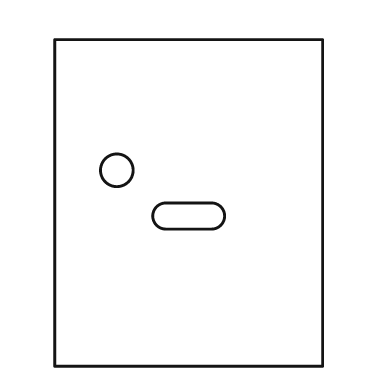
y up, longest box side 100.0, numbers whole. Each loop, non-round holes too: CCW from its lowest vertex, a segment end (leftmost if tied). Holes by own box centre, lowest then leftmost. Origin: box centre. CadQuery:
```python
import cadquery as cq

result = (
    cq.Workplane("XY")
    .moveTo(-41.0, -50.0)
    .lineTo(41.0, -50.0)
    .lineTo(41.0, 50.0)
    .lineTo(-41.0, 50.0)
    .close()
    .moveTo(-7.0, -8.0)
    .lineTo(7.0, -8.0)
    .threePointArc((11.0, -4.0), (7.0, 0.0))
    .lineTo(-7.0, 0.0)
    .threePointArc((-11.0, -4.0), (-7.0, -8.0))
    .close()
    .moveTo(-22.0, 10.0)
    .circle(5.0)
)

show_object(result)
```